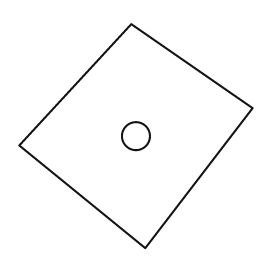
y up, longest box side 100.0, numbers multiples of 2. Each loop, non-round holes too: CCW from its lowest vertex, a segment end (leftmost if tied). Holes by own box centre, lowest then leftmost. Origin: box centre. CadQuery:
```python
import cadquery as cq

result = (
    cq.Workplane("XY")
    .moveTo(4.0, -48.0)
    .lineTo(50.0, 12.0)
    .lineTo(-2.0, 48.0)
    .lineTo(-50.0, -4.0)
    .close()
    .moveTo(0.0, 0.0)
    .circle(6.0)
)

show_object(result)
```